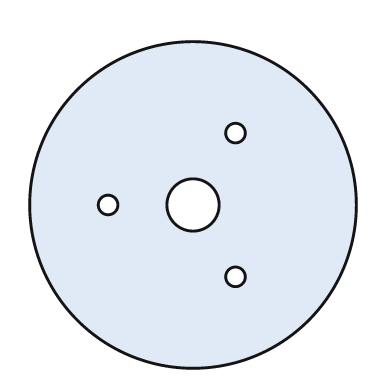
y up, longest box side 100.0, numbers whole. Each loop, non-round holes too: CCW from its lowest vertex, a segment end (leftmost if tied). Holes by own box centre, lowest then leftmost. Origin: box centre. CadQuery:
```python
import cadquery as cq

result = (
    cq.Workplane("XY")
    .moveTo(0.0, 0.0)
    .circle(50.0)
    .moveTo(13.0, -22.0)
    .circle(3.0)
    .moveTo(-26.0, 0.0)
    .circle(3.0)
    .moveTo(0.0, 0.0)
    .circle(8.0)
    .moveTo(13.0, 22.0)
    .circle(3.0)
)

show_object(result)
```